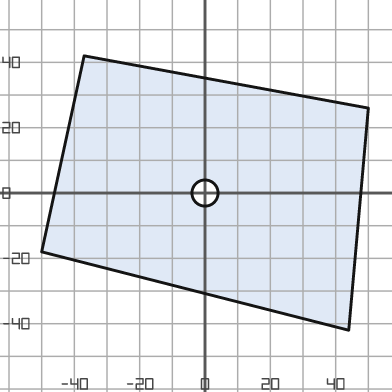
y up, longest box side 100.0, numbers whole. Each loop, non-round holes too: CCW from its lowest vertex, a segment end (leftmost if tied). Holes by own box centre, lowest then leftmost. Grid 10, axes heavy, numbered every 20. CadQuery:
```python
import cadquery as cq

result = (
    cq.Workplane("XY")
    .moveTo(44.0, -42.0)
    .lineTo(50.0, 26.0)
    .lineTo(-37.0, 42.0)
    .lineTo(-50.0, -18.0)
    .close()
    .moveTo(0.0, 0.0)
    .circle(4.0)
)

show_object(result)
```